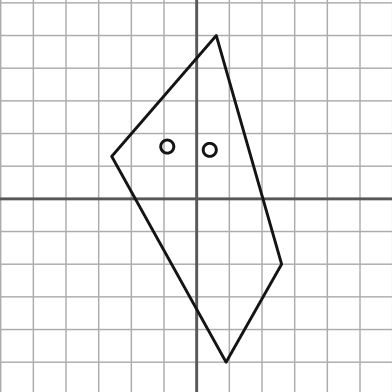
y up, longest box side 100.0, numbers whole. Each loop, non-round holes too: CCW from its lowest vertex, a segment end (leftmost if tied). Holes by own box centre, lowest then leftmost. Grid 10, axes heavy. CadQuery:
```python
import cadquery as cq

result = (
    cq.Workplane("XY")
    .moveTo(9.0, -50.0)
    .lineTo(26.0, -20.0)
    .lineTo(6.0, 50.0)
    .lineTo(-26.0, 13.0)
    .close()
    .moveTo(4.0, 15.0)
    .circle(2.0)
    .moveTo(-9.0, 16.0)
    .circle(2.0)
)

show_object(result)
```